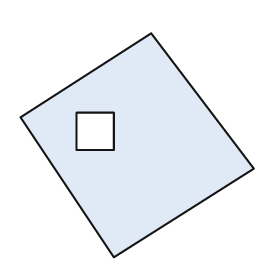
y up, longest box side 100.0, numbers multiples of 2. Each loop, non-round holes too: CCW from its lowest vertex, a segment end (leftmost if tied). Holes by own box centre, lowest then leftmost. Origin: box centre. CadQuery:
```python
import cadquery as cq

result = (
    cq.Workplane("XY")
    .moveTo(-10.0, -48.0)
    .lineTo(50.0, -10.0)
    .lineTo(6.0, 48.0)
    .lineTo(-50.0, 12.0)
    .close()
    .moveTo(-26.0, -2.0)
    .lineTo(-10.0, -2.0)
    .lineTo(-10.0, 14.0)
    .lineTo(-26.0, 14.0)
    .close()
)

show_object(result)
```